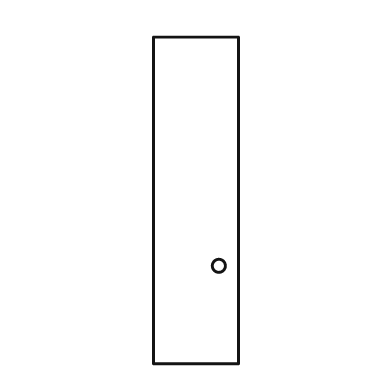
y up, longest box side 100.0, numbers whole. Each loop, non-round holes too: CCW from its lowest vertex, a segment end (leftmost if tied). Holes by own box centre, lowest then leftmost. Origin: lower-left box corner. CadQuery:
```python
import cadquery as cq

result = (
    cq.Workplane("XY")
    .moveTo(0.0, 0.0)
    .lineTo(26.0, 0.0)
    .lineTo(26.0, 100.0)
    .lineTo(0.0, 100.0)
    .close()
    .moveTo(20.0, 30.0)
    .circle(2.0)
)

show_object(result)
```